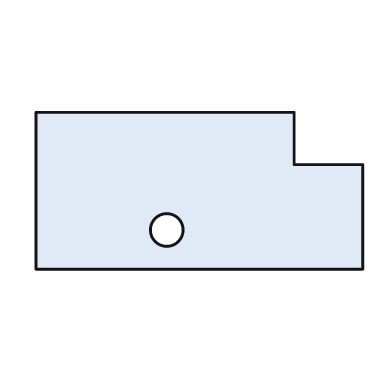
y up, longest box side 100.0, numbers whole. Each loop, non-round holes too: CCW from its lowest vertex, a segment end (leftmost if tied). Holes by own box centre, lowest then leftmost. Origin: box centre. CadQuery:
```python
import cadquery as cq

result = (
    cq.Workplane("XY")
    .moveTo(-50.0, -24.0)
    .lineTo(50.0, -24.0)
    .lineTo(50.0, 8.0)
    .lineTo(29.0, 8.0)
    .lineTo(29.0, 24.0)
    .lineTo(-50.0, 24.0)
    .close()
    .moveTo(-10.0, -12.0)
    .circle(5.0)
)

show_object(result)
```